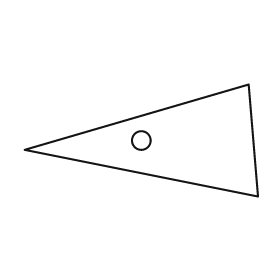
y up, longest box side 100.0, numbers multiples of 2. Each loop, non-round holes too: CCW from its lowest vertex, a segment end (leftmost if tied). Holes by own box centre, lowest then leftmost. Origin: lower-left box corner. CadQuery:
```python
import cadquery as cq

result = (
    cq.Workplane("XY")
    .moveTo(100.0, 0.0)
    .lineTo(96.0, 48.0)
    .lineTo(0.0, 20.0)
    .close()
    .moveTo(50.0, 24.0)
    .circle(4.0)
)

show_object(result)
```